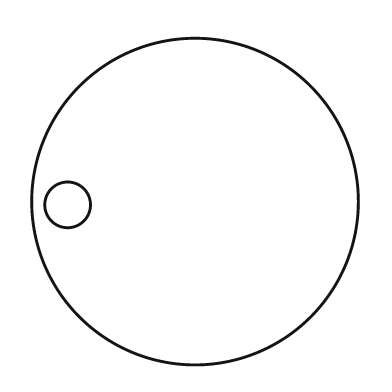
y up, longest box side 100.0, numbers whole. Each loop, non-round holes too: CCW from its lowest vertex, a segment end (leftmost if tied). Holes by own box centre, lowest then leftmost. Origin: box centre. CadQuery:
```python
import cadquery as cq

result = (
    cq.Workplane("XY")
    .moveTo(0.0, 0.0)
    .circle(50.0)
    .moveTo(-39.0, -1.0)
    .circle(7.0)
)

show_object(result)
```